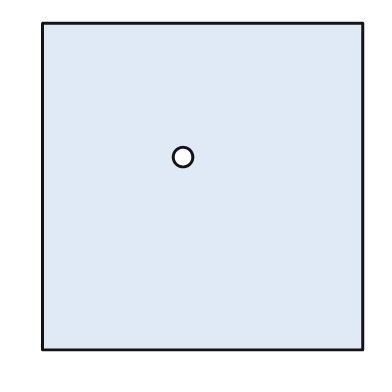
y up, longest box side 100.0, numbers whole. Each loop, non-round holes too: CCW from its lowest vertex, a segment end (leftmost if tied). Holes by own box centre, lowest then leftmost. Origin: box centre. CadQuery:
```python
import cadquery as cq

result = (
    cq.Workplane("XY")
    .moveTo(-49.0, -50.0)
    .lineTo(49.0, -50.0)
    .lineTo(49.0, 50.0)
    .lineTo(-49.0, 50.0)
    .close()
    .moveTo(-6.0, 9.0)
    .circle(3.0)
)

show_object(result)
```